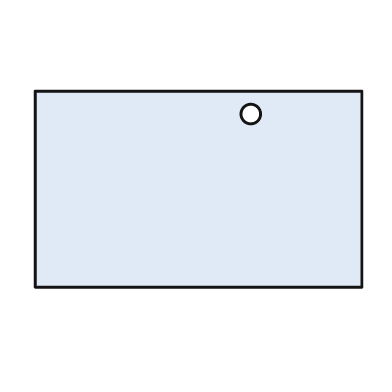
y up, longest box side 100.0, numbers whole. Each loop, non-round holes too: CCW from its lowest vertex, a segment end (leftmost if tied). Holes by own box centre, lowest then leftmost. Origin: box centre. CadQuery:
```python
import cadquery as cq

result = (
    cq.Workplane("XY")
    .moveTo(-50.0, -30.0)
    .lineTo(50.0, -30.0)
    .lineTo(50.0, 30.0)
    .lineTo(-50.0, 30.0)
    .close()
    .moveTo(16.0, 23.0)
    .circle(3.0)
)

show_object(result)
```